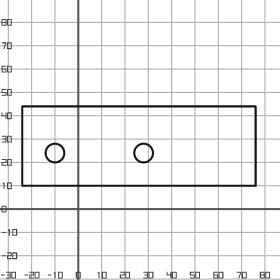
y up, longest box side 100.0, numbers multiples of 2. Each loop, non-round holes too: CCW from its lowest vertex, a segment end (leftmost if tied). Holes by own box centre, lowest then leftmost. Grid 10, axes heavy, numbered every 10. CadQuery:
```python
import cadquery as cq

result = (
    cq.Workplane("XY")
    .moveTo(-24.0, 10.0)
    .lineTo(76.0, 10.0)
    .lineTo(76.0, 44.0)
    .lineTo(-24.0, 44.0)
    .close()
    .moveTo(-10.0, 24.0)
    .circle(4.0)
    .moveTo(28.0, 24.0)
    .circle(4.0)
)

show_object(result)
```